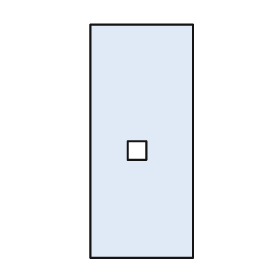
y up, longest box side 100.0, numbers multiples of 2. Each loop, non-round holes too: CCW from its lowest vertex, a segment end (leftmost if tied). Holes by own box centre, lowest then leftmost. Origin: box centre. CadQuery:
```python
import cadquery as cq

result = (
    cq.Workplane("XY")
    .moveTo(-22.0, -50.0)
    .lineTo(22.0, -50.0)
    .lineTo(22.0, 50.0)
    .lineTo(-22.0, 50.0)
    .close()
    .moveTo(-6.0, -8.0)
    .lineTo(2.0, -8.0)
    .lineTo(2.0, 0.0)
    .lineTo(-6.0, 0.0)
    .close()
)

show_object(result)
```